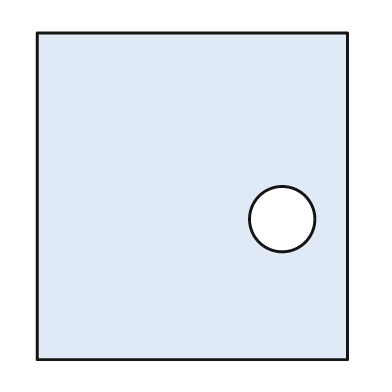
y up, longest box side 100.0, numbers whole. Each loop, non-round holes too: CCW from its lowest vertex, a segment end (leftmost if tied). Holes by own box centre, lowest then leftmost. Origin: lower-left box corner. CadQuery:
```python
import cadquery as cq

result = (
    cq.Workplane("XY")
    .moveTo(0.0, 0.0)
    .lineTo(95.0, 0.0)
    .lineTo(95.0, 100.0)
    .lineTo(0.0, 100.0)
    .close()
    .moveTo(75.0, 43.0)
    .circle(10.0)
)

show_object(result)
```